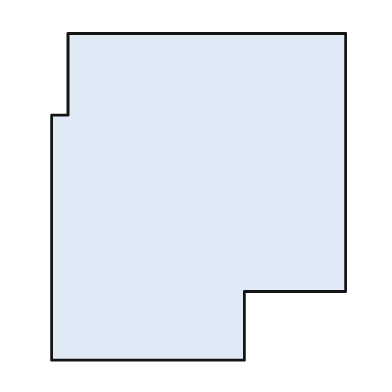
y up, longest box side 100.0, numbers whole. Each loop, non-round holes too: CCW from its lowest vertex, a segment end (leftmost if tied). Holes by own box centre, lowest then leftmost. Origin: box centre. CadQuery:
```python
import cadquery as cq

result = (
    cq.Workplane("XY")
    .moveTo(-45.0, -50.0)
    .lineTo(14.0, -50.0)
    .lineTo(14.0, -29.0)
    .lineTo(45.0, -29.0)
    .lineTo(45.0, 50.0)
    .lineTo(-40.0, 50.0)
    .lineTo(-40.0, 25.0)
    .lineTo(-45.0, 25.0)
    .close()
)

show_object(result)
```